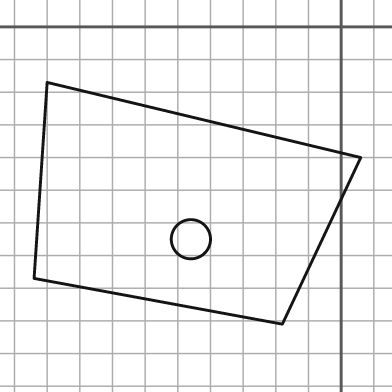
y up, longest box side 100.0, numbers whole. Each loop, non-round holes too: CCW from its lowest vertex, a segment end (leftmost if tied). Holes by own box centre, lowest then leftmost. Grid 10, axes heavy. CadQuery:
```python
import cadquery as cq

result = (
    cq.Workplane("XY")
    .moveTo(-18.0, -91.0)
    .lineTo(6.0, -40.0)
    .lineTo(-90.0, -17.0)
    .lineTo(-94.0, -77.0)
    .close()
    .moveTo(-46.0, -65.0)
    .circle(6.0)
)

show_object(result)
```